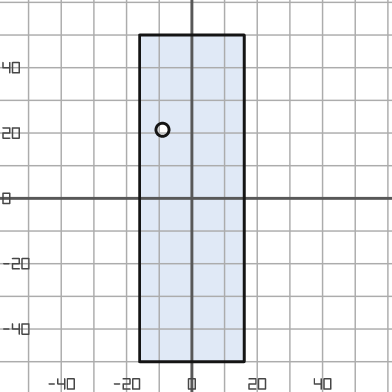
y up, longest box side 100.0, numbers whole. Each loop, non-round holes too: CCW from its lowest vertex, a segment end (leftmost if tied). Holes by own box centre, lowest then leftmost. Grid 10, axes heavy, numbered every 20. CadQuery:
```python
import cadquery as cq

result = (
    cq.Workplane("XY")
    .moveTo(-16.0, -50.0)
    .lineTo(16.0, -50.0)
    .lineTo(16.0, 50.0)
    .lineTo(-16.0, 50.0)
    .close()
    .moveTo(-9.0, 21.0)
    .circle(2.0)
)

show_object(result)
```